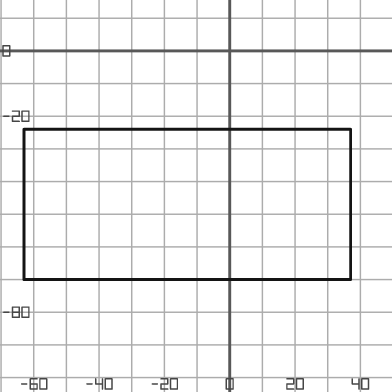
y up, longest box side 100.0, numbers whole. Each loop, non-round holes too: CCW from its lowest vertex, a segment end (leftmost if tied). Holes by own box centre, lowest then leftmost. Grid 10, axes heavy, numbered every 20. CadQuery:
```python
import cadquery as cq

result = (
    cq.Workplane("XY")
    .moveTo(-63.0, -70.0)
    .lineTo(37.0, -70.0)
    .lineTo(37.0, -24.0)
    .lineTo(-63.0, -24.0)
    .close()
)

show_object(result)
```